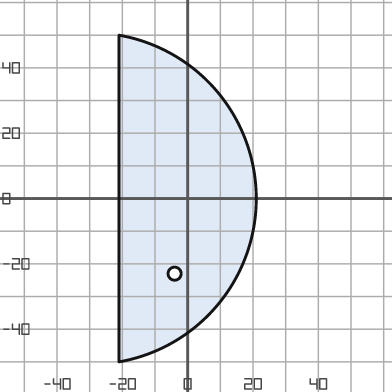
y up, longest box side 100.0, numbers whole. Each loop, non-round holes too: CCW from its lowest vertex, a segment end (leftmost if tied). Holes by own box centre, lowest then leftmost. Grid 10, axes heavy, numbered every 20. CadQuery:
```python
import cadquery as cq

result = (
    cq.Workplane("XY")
    .moveTo(-21.0, -50.0)
    .threePointArc((21.0, 0.0), (-21.0, 50.0))
    .close()
    .moveTo(-4.0, -23.0)
    .circle(2.0)
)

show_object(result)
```